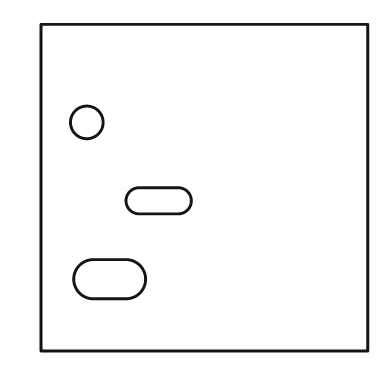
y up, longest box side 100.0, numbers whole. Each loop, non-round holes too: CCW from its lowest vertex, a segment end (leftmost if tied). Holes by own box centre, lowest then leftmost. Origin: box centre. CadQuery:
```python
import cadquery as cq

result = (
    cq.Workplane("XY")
    .moveTo(-50.0, -50.0)
    .lineTo(50.0, -50.0)
    .lineTo(50.0, 50.0)
    .lineTo(-50.0, 50.0)
    .close()
    .moveTo(-34.0, -34.0)
    .lineTo(-24.0, -34.0)
    .threePointArc((-18.0, -28.0), (-24.0, -22.0))
    .lineTo(-34.0, -22.0)
    .threePointArc((-40.0, -28.0), (-34.0, -34.0))
    .close()
    .moveTo(-20.0, -8.0)
    .lineTo(-8.0, -8.0)
    .threePointArc((-4.0, -4.0), (-8.0, 0.0))
    .lineTo(-20.0, 0.0)
    .threePointArc((-24.0, -4.0), (-20.0, -8.0))
    .close()
    .moveTo(-36.0, 20.0)
    .circle(5.0)
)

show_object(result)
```